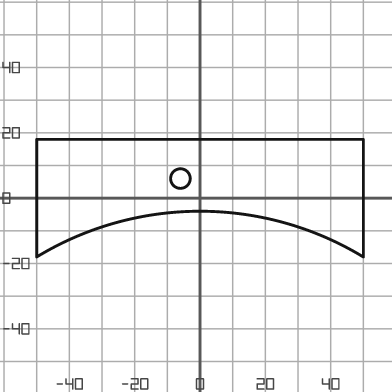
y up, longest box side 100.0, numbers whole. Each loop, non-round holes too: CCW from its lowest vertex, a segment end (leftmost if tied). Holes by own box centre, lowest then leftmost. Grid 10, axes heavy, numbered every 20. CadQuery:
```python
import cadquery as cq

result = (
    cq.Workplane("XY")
    .moveTo(-50.0, -18.0)
    .threePointArc((0.0, -4.0), (50.0, -18.0))
    .lineTo(50.0, 18.0)
    .lineTo(-50.0, 18.0)
    .close()
    .moveTo(-6.0, 6.0)
    .circle(3.0)
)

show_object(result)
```